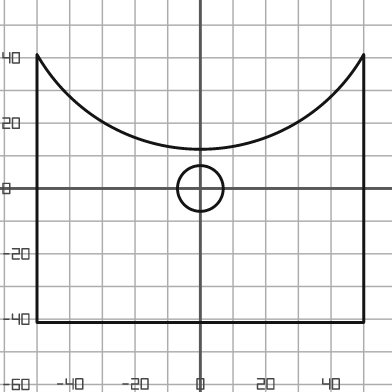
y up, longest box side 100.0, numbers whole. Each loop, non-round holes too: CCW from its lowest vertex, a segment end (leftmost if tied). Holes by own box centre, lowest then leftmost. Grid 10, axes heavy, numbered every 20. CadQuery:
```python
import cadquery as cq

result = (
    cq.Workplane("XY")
    .moveTo(-50.0, -41.0)
    .lineTo(50.0, -41.0)
    .lineTo(50.0, 41.0)
    .threePointArc((0.0, 12.0), (-50.0, 41.0))
    .close()
    .moveTo(0.0, 0.0)
    .circle(7.0)
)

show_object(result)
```